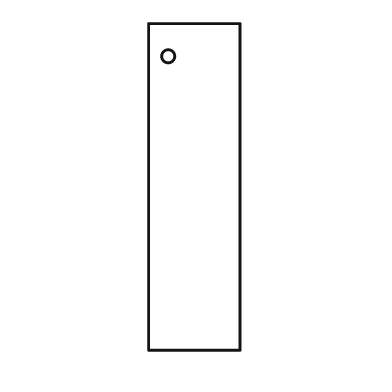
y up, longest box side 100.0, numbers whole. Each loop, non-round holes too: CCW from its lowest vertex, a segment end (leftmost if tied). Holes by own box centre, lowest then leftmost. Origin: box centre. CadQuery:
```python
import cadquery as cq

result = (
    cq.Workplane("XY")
    .moveTo(-14.0, -50.0)
    .lineTo(14.0, -50.0)
    .lineTo(14.0, 50.0)
    .lineTo(-14.0, 50.0)
    .close()
    .moveTo(-8.0, 40.0)
    .circle(2.0)
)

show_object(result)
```